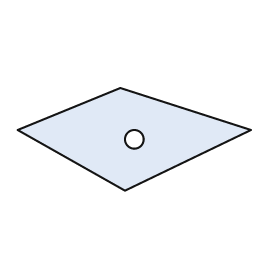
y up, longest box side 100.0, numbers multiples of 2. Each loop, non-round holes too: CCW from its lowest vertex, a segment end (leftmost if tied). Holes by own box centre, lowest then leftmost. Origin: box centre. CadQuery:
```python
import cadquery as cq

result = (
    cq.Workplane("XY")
    .moveTo(-4.0, -22.0)
    .lineTo(50.0, 4.0)
    .lineTo(-6.0, 22.0)
    .lineTo(-50.0, 4.0)
    .close()
    .moveTo(0.0, 0.0)
    .circle(4.0)
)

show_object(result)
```